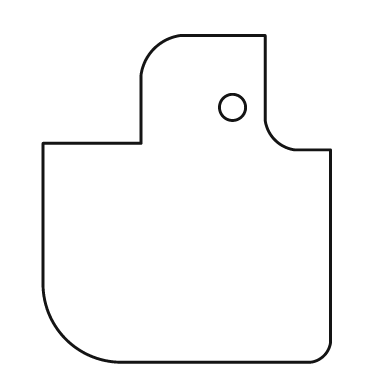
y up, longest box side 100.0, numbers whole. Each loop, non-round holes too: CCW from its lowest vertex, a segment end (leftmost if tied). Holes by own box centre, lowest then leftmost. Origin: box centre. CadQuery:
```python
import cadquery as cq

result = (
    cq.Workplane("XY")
    .moveTo(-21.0, -50.0)
    .lineTo(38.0, -50.0)
    .threePointArc((42.0, -48.0), (44.0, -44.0))
    .lineTo(44.0, 15.0)
    .lineTo(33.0, 15.0)
    .threePointArc((27.0, 18.0), (24.0, 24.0))
    .lineTo(24.0, 50.0)
    .lineTo(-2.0, 50.0)
    .threePointArc((-10.0, 46.0), (-14.0, 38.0))
    .lineTo(-14.0, 17.0)
    .lineTo(-44.0, 17.0)
    .lineTo(-44.0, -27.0)
    .threePointArc((-37.0, -43.0), (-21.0, -50.0))
    .close()
    .moveTo(14.0, 28.0)
    .circle(4.0)
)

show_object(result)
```